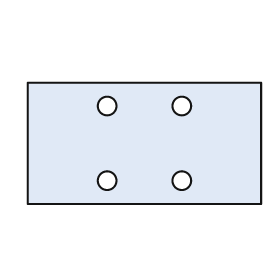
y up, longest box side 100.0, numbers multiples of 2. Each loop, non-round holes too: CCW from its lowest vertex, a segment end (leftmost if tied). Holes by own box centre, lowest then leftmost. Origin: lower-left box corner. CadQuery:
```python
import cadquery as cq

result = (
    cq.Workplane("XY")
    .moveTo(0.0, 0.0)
    .lineTo(100.0, 0.0)
    .lineTo(100.0, 52.0)
    .lineTo(0.0, 52.0)
    .close()
    .moveTo(34.0, 10.0)
    .circle(4.0)
    .moveTo(66.0, 10.0)
    .circle(4.0)
    .moveTo(34.0, 42.0)
    .circle(4.0)
    .moveTo(66.0, 42.0)
    .circle(4.0)
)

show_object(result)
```